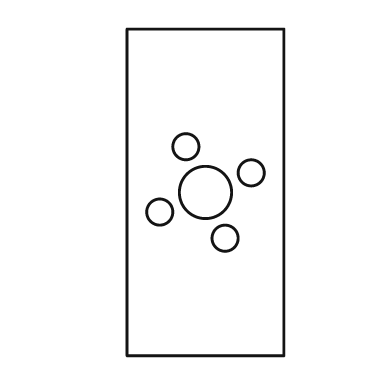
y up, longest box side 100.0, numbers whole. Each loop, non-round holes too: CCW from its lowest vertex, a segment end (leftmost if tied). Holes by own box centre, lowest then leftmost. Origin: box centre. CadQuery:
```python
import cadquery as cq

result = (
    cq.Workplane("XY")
    .moveTo(-24.0, -50.0)
    .lineTo(24.0, -50.0)
    .lineTo(24.0, 50.0)
    .lineTo(-24.0, 50.0)
    .close()
    .moveTo(6.0, -14.0)
    .circle(4.0)
    .moveTo(-14.0, -6.0)
    .circle(4.0)
    .moveTo(0.0, 0.0)
    .circle(8.0)
    .moveTo(14.0, 6.0)
    .circle(4.0)
    .moveTo(-6.0, 14.0)
    .circle(4.0)
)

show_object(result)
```